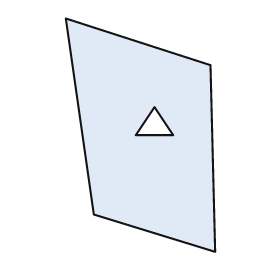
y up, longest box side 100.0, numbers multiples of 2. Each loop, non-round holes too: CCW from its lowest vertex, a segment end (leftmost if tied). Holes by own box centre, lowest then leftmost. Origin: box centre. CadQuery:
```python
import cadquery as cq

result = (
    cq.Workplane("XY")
    .moveTo(32.0, -50.0)
    .lineTo(30.0, 30.0)
    .lineTo(-32.0, 50.0)
    .lineTo(-20.0, -34.0)
    .close()
    .moveTo(-2.0, 0.0)
    .lineTo(14.0, 0.0)
    .lineTo(6.0, 12.0)
    .close()
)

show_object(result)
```